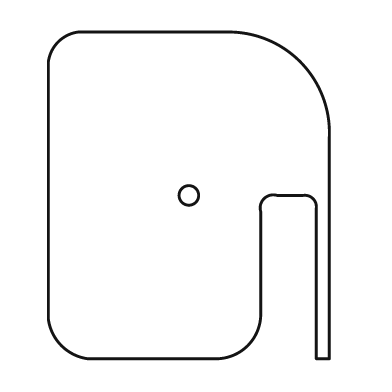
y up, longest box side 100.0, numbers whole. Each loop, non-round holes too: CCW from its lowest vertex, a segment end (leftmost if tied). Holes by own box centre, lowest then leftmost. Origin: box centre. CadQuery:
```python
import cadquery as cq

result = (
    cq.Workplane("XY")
    .moveTo(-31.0, -50.0)
    .lineTo(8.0, -50.0)
    .threePointArc((18.0, -46.0), (22.0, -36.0))
    .lineTo(22.0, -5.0)
    .threePointArc((23.0, -1.0), (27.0, 0.0))
    .lineTo(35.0, 0.0)
    .threePointArc((38.0, -1.0), (39.0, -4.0))
    .lineTo(39.0, -50.0)
    .lineTo(43.0, -50.0)
    .lineTo(43.0, 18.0)
    .threePointArc((34.0, 41.0), (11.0, 50.0))
    .lineTo(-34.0, 50.0)
    .threePointArc((-40.0, 47.0), (-43.0, 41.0))
    .lineTo(-43.0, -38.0)
    .threePointArc((-39.0, -46.0), (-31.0, -50.0))
    .close()
    .moveTo(0.0, 0.0)
    .circle(3.0)
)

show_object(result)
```